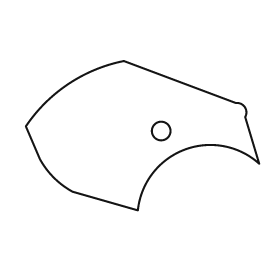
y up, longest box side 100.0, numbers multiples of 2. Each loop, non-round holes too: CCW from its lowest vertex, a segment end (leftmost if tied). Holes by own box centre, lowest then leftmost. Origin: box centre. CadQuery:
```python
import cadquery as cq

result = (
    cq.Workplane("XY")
    .moveTo(-2.0, -32.0)
    .threePointArc((18.0, -6.0), (50.0, -12.0))
    .lineTo(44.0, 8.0)
    .threePointArc((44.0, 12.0), (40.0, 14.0))
    .lineTo(-8.0, 32.0)
    .threePointArc((-32.0, 22.0), (-50.0, 4.0))
    .lineTo(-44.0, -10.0)
    .threePointArc((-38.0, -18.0), (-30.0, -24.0))
    .close()
    .moveTo(8.0, 2.0)
    .circle(4.0)
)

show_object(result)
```